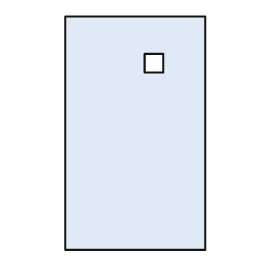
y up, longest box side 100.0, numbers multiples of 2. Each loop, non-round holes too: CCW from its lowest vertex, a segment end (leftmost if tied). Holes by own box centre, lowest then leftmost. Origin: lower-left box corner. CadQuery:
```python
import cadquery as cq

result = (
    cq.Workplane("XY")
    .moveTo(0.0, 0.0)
    .lineTo(60.0, 0.0)
    .lineTo(60.0, 100.0)
    .lineTo(0.0, 100.0)
    .close()
    .moveTo(34.0, 76.0)
    .lineTo(42.0, 76.0)
    .lineTo(42.0, 84.0)
    .lineTo(34.0, 84.0)
    .close()
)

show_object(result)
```